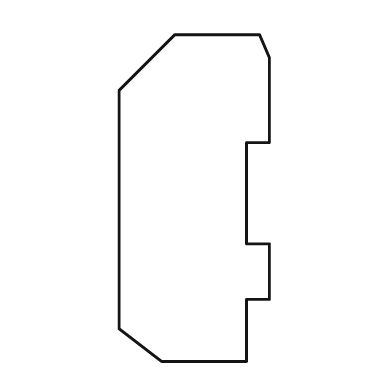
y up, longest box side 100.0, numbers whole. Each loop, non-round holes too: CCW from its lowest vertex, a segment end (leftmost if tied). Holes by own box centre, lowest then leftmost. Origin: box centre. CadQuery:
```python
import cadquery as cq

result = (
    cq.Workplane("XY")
    .moveTo(-10.0, -50.0)
    .lineTo(16.0, -50.0)
    .lineTo(16.0, -31.0)
    .lineTo(23.0, -31.0)
    .lineTo(23.0, -14.0)
    .lineTo(16.0, -14.0)
    .lineTo(16.0, 17.0)
    .lineTo(23.0, 17.0)
    .lineTo(23.0, 43.0)
    .lineTo(20.0, 50.0)
    .lineTo(-6.0, 50.0)
    .lineTo(-23.0, 33.0)
    .lineTo(-23.0, -40.0)
    .close()
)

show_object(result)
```